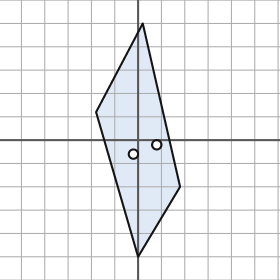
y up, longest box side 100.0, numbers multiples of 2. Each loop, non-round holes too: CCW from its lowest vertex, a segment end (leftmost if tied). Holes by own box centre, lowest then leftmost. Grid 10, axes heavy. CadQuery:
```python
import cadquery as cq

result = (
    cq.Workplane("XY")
    .moveTo(0.0, -50.0)
    .lineTo(18.0, -20.0)
    .lineTo(2.0, 50.0)
    .lineTo(-18.0, 12.0)
    .close()
    .moveTo(-2.0, -6.0)
    .circle(2.0)
    .moveTo(8.0, -2.0)
    .circle(2.0)
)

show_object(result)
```